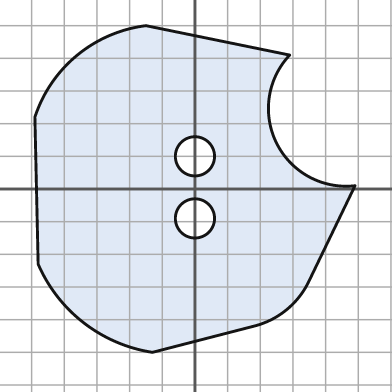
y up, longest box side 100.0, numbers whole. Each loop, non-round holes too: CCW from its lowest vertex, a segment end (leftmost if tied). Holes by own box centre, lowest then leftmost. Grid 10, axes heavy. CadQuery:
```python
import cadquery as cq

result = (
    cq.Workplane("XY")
    .moveTo(-13.0, -50.0)
    .lineTo(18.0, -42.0)
    .threePointArc((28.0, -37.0), (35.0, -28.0))
    .lineTo(49.0, 1.0)
    .threePointArc((25.0, 14.0), (29.0, 41.0))
    .lineTo(-15.0, 50.0)
    .threePointArc((-36.0, 41.0), (-49.0, 22.0))
    .lineTo(-48.0, -23.0)
    .threePointArc((-34.0, -41.0), (-13.0, -50.0))
    .close()
    .moveTo(0.0, -9.0)
    .circle(6.0)
    .moveTo(0.0, 10.0)
    .circle(6.0)
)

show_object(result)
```